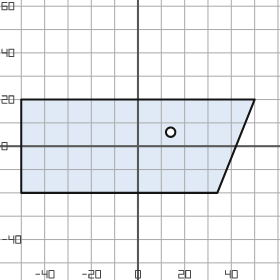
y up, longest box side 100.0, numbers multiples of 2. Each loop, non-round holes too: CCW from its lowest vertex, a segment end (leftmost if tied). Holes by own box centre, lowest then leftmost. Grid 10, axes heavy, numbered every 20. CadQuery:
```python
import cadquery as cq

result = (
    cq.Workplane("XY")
    .moveTo(-50.0, -20.0)
    .lineTo(34.0, -20.0)
    .lineTo(50.0, 20.0)
    .lineTo(-50.0, 20.0)
    .close()
    .moveTo(14.0, 6.0)
    .circle(2.0)
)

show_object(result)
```